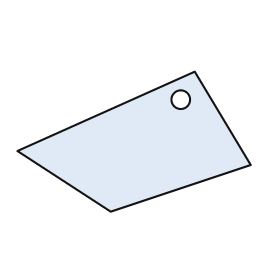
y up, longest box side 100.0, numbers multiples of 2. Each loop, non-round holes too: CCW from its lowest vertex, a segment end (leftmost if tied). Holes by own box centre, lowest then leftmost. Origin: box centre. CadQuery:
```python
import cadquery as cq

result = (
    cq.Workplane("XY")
    .moveTo(-10.0, -30.0)
    .lineTo(50.0, -10.0)
    .lineTo(26.0, 30.0)
    .lineTo(-50.0, -4.0)
    .close()
    .moveTo(20.0, 18.0)
    .circle(4.0)
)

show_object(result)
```